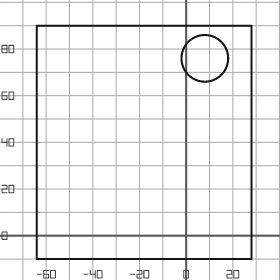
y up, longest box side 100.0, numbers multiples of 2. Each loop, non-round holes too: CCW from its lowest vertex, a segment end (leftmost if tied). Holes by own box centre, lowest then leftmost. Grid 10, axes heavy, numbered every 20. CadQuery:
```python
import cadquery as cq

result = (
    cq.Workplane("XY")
    .moveTo(-64.0, -10.0)
    .lineTo(28.0, -10.0)
    .lineTo(28.0, 90.0)
    .lineTo(-64.0, 90.0)
    .close()
    .moveTo(8.0, 76.0)
    .circle(10.0)
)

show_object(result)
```